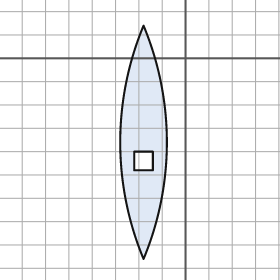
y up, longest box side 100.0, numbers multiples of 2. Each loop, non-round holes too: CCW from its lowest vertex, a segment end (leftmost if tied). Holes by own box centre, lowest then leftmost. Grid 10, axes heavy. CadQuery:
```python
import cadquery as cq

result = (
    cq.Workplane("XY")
    .moveTo(-18.0, -86.0)
    .threePointArc((-8.0, -36.0), (-18.0, 14.0))
    .threePointArc((-28.0, -36.0), (-18.0, -86.0))
    .close()
    .moveTo(-22.0, -48.0)
    .lineTo(-14.0, -48.0)
    .lineTo(-14.0, -40.0)
    .lineTo(-22.0, -40.0)
    .close()
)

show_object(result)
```